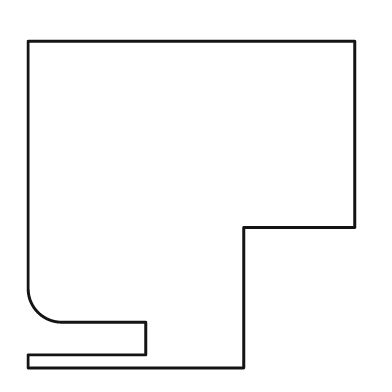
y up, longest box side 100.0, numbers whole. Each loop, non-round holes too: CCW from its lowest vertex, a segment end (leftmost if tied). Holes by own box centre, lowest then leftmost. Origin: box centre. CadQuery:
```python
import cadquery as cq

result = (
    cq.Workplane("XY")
    .moveTo(-50.0, -50.0)
    .lineTo(16.0, -50.0)
    .lineTo(16.0, -7.0)
    .lineTo(50.0, -7.0)
    .lineTo(50.0, 50.0)
    .lineTo(-50.0, 50.0)
    .lineTo(-50.0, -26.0)
    .threePointArc((-47.0, -33.0), (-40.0, -36.0))
    .lineTo(-14.0, -36.0)
    .lineTo(-14.0, -46.0)
    .lineTo(-50.0, -46.0)
    .close()
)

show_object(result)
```